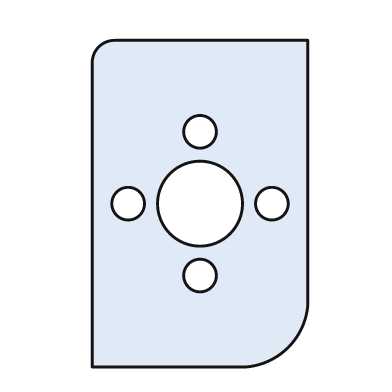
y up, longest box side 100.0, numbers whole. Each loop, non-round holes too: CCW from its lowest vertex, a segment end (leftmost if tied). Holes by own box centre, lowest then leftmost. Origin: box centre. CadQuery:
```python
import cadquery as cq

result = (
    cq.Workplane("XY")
    .moveTo(-33.0, -50.0)
    .lineTo(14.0, -50.0)
    .threePointArc((27.0, -44.0), (33.0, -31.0))
    .lineTo(33.0, 50.0)
    .lineTo(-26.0, 50.0)
    .threePointArc((-31.0, 48.0), (-33.0, 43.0))
    .close()
    .moveTo(0.0, -22.0)
    .circle(5.0)
    .moveTo(-22.0, 0.0)
    .circle(5.0)
    .moveTo(0.0, 0.0)
    .circle(13.0)
    .moveTo(22.0, 0.0)
    .circle(5.0)
    .moveTo(0.0, 22.0)
    .circle(5.0)
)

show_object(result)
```